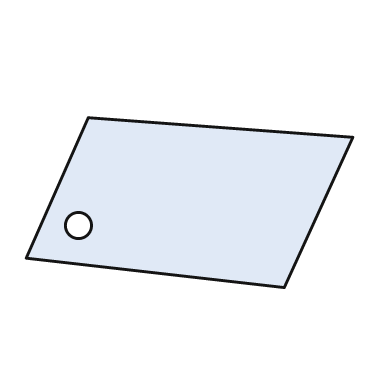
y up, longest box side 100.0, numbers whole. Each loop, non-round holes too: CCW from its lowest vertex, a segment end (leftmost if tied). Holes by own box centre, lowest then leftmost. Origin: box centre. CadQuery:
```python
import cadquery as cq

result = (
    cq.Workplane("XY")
    .moveTo(29.0, -26.0)
    .lineTo(50.0, 20.0)
    .lineTo(-31.0, 26.0)
    .lineTo(-50.0, -17.0)
    .close()
    .moveTo(-34.0, -7.0)
    .circle(4.0)
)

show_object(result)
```